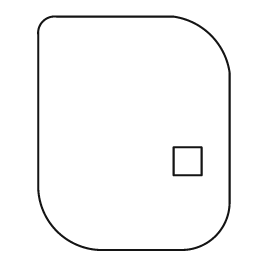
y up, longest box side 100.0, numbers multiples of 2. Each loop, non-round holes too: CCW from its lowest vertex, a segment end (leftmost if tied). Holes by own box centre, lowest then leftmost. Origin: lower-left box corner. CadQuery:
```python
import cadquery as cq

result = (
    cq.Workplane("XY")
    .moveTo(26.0, 0.0)
    .lineTo(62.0, 0.0)
    .threePointArc((76.0, 6.0), (82.0, 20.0))
    .lineTo(82.0, 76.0)
    .threePointArc((74.0, 92.0), (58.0, 100.0))
    .lineTo(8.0, 100.0)
    .threePointArc((2.0, 98.0), (0.0, 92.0))
    .lineTo(0.0, 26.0)
    .threePointArc((8.0, 8.0), (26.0, 0.0))
    .close()
    .moveTo(58.0, 32.0)
    .lineTo(70.0, 32.0)
    .lineTo(70.0, 44.0)
    .lineTo(58.0, 44.0)
    .close()
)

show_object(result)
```